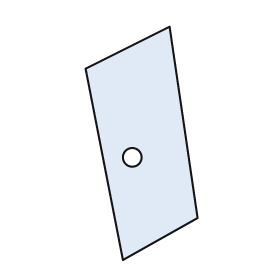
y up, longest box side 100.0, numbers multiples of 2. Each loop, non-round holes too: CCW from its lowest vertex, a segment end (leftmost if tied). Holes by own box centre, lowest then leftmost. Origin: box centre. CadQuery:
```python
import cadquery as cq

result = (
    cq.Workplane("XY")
    .moveTo(-8.0, -50.0)
    .lineTo(24.0, -32.0)
    .lineTo(12.0, 50.0)
    .lineTo(-24.0, 32.0)
    .close()
    .moveTo(-4.0, -6.0)
    .circle(4.0)
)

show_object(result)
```